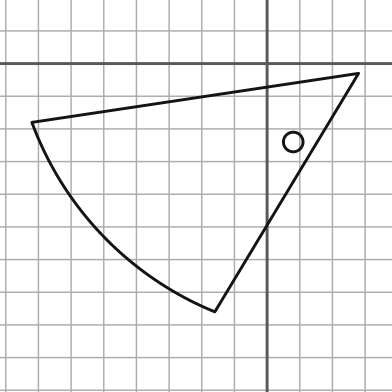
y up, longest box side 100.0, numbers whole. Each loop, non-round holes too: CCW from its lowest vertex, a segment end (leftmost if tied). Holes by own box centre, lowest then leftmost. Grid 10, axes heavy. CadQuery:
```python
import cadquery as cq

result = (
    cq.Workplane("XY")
    .moveTo(-16.0, -76.0)
    .lineTo(28.0, -3.0)
    .lineTo(-72.0, -18.0)
    .threePointArc((-50.0, -53.0), (-16.0, -76.0))
    .close()
    .moveTo(8.0, -24.0)
    .circle(3.0)
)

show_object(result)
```